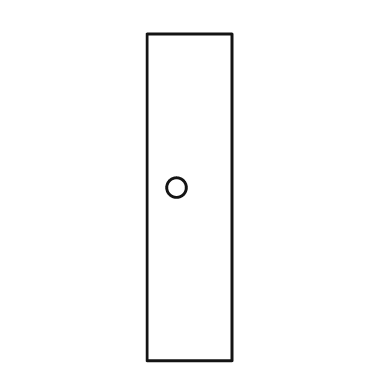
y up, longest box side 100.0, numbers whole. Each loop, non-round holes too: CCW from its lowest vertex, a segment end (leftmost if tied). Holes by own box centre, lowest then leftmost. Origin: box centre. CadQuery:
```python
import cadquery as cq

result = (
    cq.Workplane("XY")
    .moveTo(-13.0, -50.0)
    .lineTo(13.0, -50.0)
    .lineTo(13.0, 50.0)
    .lineTo(-13.0, 50.0)
    .close()
    .moveTo(-4.0, 3.0)
    .circle(3.0)
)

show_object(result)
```